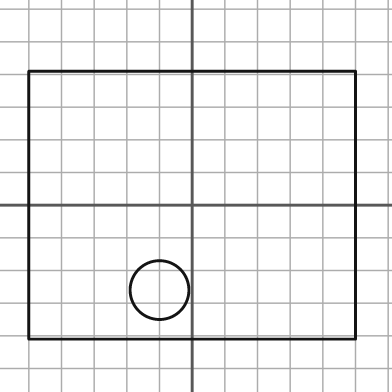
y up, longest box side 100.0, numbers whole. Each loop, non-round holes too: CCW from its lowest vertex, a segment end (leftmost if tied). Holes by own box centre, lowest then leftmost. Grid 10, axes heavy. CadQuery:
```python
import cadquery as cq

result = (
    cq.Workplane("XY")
    .moveTo(-50.0, -41.0)
    .lineTo(50.0, -41.0)
    .lineTo(50.0, 41.0)
    .lineTo(-50.0, 41.0)
    .close()
    .moveTo(-10.0, -26.0)
    .circle(9.0)
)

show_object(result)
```